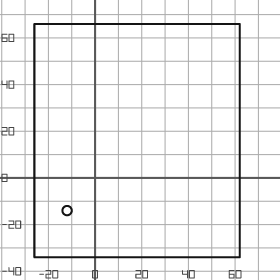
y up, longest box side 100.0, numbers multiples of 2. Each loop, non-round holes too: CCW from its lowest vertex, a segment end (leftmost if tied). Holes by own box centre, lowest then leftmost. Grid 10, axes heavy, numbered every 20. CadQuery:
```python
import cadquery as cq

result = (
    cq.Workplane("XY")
    .moveTo(-26.0, -34.0)
    .lineTo(62.0, -34.0)
    .lineTo(62.0, 66.0)
    .lineTo(-26.0, 66.0)
    .close()
    .moveTo(-12.0, -14.0)
    .circle(2.0)
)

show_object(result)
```